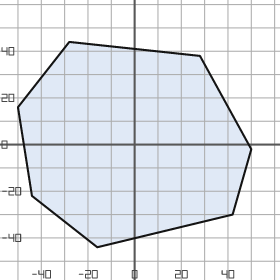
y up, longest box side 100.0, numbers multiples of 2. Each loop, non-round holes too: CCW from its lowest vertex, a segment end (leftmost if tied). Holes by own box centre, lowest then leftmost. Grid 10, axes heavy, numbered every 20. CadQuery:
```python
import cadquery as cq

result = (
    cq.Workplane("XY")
    .moveTo(-16.0, -44.0)
    .lineTo(42.0, -30.0)
    .lineTo(50.0, -2.0)
    .lineTo(28.0, 38.0)
    .lineTo(-28.0, 44.0)
    .lineTo(-50.0, 16.0)
    .lineTo(-44.0, -22.0)
    .close()
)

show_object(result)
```